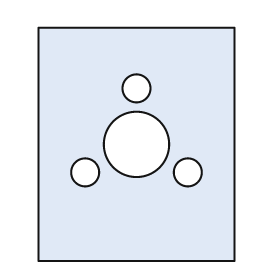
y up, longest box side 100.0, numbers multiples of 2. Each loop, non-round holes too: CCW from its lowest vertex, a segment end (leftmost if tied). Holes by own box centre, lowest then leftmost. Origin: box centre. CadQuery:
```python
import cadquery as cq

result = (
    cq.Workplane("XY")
    .moveTo(-42.0, -50.0)
    .lineTo(42.0, -50.0)
    .lineTo(42.0, 50.0)
    .lineTo(-42.0, 50.0)
    .close()
    .moveTo(-22.0, -12.0)
    .circle(6.0)
    .moveTo(22.0, -12.0)
    .circle(6.0)
    .moveTo(0.0, 0.0)
    .circle(14.0)
    .moveTo(0.0, 24.0)
    .circle(6.0)
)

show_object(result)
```